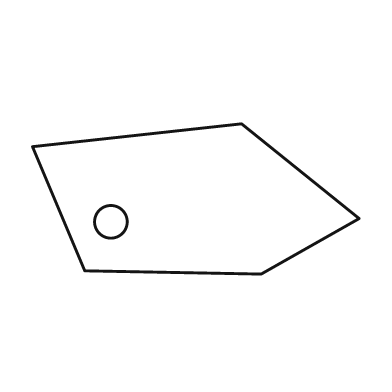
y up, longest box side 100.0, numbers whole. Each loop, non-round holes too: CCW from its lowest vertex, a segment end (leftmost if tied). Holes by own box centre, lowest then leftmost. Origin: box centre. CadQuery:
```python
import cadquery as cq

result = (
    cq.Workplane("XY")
    .moveTo(20.0, -23.0)
    .lineTo(50.0, -6.0)
    .lineTo(14.0, 23.0)
    .lineTo(-50.0, 16.0)
    .lineTo(-34.0, -22.0)
    .close()
    .moveTo(-26.0, -7.0)
    .circle(5.0)
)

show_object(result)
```